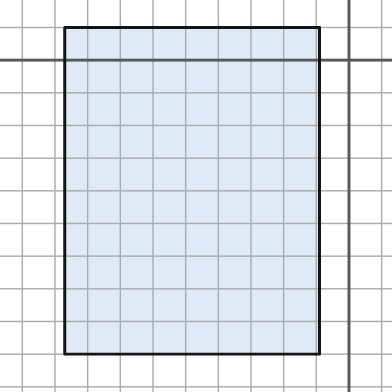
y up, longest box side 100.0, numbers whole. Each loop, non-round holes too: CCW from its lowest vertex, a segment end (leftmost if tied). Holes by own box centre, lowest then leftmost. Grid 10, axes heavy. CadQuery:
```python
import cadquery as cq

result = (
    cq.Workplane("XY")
    .moveTo(-87.0, -90.0)
    .lineTo(-9.0, -90.0)
    .lineTo(-9.0, 10.0)
    .lineTo(-87.0, 10.0)
    .close()
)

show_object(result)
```